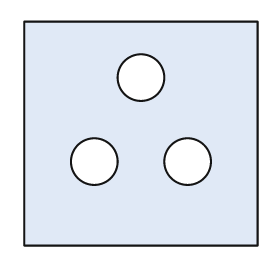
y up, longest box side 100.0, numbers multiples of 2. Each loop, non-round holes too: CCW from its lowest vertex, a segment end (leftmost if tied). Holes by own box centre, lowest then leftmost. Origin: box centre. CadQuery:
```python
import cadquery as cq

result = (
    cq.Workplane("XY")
    .moveTo(-50.0, -48.0)
    .lineTo(50.0, -48.0)
    .lineTo(50.0, 48.0)
    .lineTo(-50.0, 48.0)
    .close()
    .moveTo(-20.0, -12.0)
    .circle(10.0)
    .moveTo(20.0, -12.0)
    .circle(10.0)
    .moveTo(0.0, 24.0)
    .circle(10.0)
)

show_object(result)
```